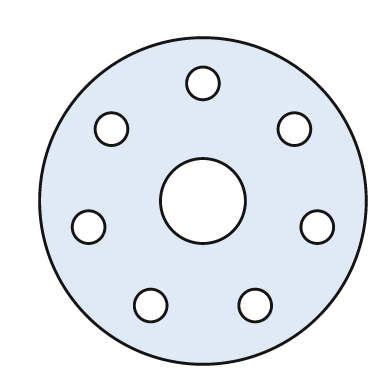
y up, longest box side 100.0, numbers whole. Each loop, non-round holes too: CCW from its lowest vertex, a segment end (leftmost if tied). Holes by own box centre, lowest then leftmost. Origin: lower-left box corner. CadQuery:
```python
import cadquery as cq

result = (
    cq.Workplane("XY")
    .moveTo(50.0, 50.0)
    .circle(50.0)
    .moveTo(34.0, 18.0)
    .circle(5.0)
    .moveTo(66.0, 18.0)
    .circle(5.0)
    .moveTo(15.0, 42.0)
    .circle(5.0)
    .moveTo(85.0, 42.0)
    .circle(5.0)
    .moveTo(50.0, 50.0)
    .circle(13.0)
    .moveTo(22.0, 72.0)
    .circle(5.0)
    .moveTo(78.0, 72.0)
    .circle(5.0)
    .moveTo(50.0, 86.0)
    .circle(5.0)
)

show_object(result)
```